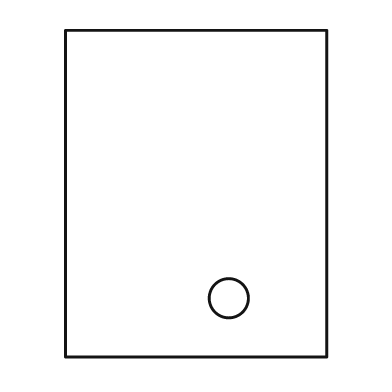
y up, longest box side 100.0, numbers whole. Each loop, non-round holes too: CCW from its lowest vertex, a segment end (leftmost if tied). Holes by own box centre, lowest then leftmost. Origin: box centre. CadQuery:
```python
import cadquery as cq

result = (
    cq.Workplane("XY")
    .moveTo(-40.0, -50.0)
    .lineTo(40.0, -50.0)
    .lineTo(40.0, 50.0)
    .lineTo(-40.0, 50.0)
    .close()
    .moveTo(10.0, -32.0)
    .circle(6.0)
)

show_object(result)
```